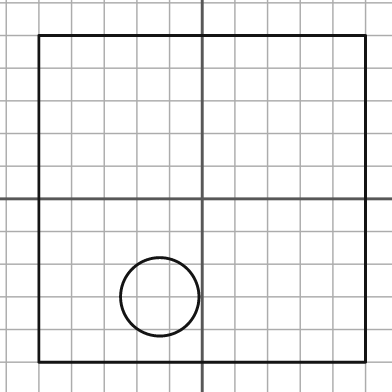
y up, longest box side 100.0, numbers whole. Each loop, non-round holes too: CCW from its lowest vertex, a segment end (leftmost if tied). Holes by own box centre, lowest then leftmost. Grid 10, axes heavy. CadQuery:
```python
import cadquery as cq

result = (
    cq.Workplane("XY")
    .moveTo(-50.0, -50.0)
    .lineTo(50.0, -50.0)
    .lineTo(50.0, 50.0)
    .lineTo(-50.0, 50.0)
    .close()
    .moveTo(-13.0, -30.0)
    .circle(12.0)
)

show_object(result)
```